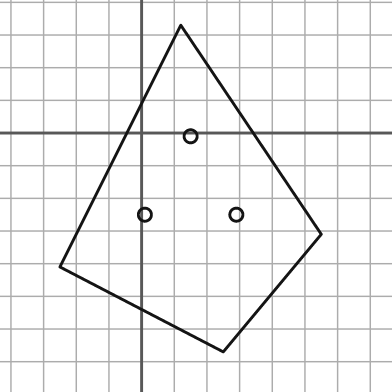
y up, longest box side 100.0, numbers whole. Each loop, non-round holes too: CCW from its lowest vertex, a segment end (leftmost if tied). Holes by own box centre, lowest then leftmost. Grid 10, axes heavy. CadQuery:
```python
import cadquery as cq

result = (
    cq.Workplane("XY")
    .moveTo(25.0, -67.0)
    .lineTo(55.0, -31.0)
    .lineTo(12.0, 33.0)
    .lineTo(-25.0, -41.0)
    .close()
    .moveTo(1.0, -25.0)
    .circle(2.0)
    .moveTo(29.0, -25.0)
    .circle(2.0)
    .moveTo(15.0, -1.0)
    .circle(2.0)
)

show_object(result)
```